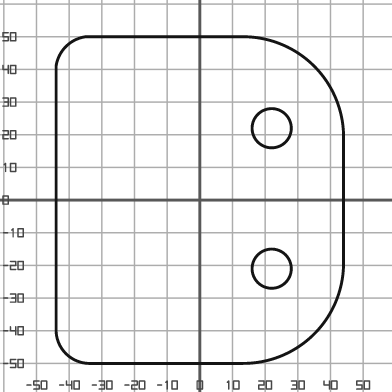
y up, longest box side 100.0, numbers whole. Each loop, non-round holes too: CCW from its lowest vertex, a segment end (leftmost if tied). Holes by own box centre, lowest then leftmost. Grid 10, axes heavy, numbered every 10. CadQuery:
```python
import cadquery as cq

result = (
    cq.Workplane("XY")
    .moveTo(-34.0, -50.0)
    .lineTo(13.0, -50.0)
    .threePointArc((35.0, -41.0), (44.0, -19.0))
    .lineTo(44.0, 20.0)
    .threePointArc((35.0, 41.0), (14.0, 50.0))
    .lineTo(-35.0, 50.0)
    .threePointArc((-41.0, 47.0), (-44.0, 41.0))
    .lineTo(-44.0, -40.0)
    .threePointArc((-41.0, -47.0), (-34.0, -50.0))
    .close()
    .moveTo(22.0, -21.0)
    .circle(6.0)
    .moveTo(22.0, 22.0)
    .circle(6.0)
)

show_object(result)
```